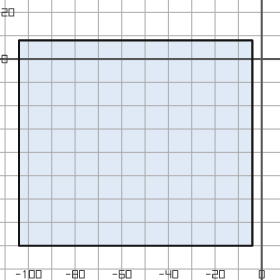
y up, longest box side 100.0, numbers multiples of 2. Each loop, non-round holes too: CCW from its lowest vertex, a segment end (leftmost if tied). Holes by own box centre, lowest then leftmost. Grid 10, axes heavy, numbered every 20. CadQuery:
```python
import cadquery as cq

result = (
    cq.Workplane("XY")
    .moveTo(-104.0, -80.0)
    .lineTo(-4.0, -80.0)
    .lineTo(-4.0, 8.0)
    .lineTo(-104.0, 8.0)
    .close()
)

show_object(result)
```